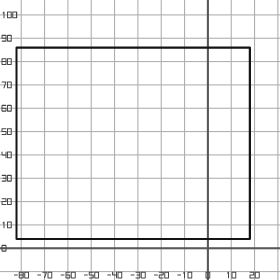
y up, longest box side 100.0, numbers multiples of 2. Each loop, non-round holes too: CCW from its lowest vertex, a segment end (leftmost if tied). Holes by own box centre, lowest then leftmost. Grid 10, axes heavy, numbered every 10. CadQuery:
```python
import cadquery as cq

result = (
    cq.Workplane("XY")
    .moveTo(-82.0, 4.0)
    .lineTo(18.0, 4.0)
    .lineTo(18.0, 86.0)
    .lineTo(-82.0, 86.0)
    .close()
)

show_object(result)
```